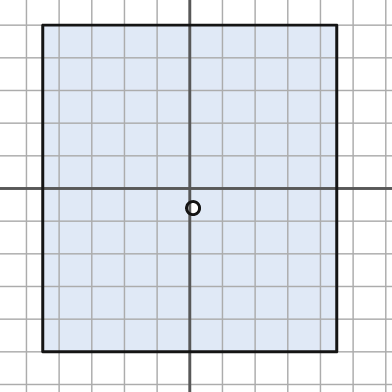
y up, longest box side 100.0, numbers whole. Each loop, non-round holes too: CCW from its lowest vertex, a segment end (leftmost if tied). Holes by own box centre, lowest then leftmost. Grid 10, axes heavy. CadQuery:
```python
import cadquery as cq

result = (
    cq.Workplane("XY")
    .moveTo(-45.0, -50.0)
    .lineTo(45.0, -50.0)
    .lineTo(45.0, 50.0)
    .lineTo(-45.0, 50.0)
    .close()
    .moveTo(1.0, -6.0)
    .circle(2.0)
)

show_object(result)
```